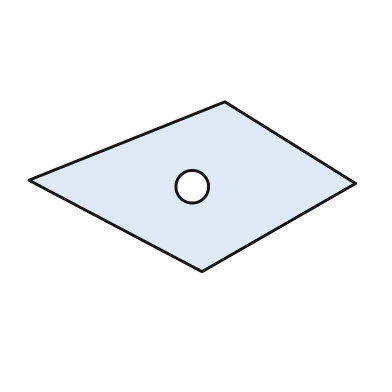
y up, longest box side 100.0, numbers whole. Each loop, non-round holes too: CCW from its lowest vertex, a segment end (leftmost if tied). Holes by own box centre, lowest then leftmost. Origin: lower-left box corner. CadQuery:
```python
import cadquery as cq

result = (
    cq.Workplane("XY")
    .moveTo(53.0, 0.0)
    .lineTo(100.0, 27.0)
    .lineTo(60.0, 52.0)
    .lineTo(0.0, 28.0)
    .close()
    .moveTo(50.0, 26.0)
    .circle(5.0)
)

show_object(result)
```